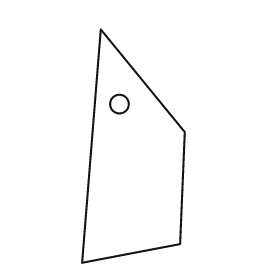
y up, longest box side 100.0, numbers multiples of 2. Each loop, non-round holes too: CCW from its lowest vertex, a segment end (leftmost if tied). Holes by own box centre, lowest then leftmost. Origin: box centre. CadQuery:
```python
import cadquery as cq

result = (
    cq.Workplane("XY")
    .moveTo(-22.0, -50.0)
    .lineTo(20.0, -42.0)
    .lineTo(22.0, 6.0)
    .lineTo(-14.0, 50.0)
    .close()
    .moveTo(-6.0, 18.0)
    .circle(4.0)
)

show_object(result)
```